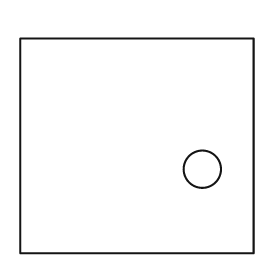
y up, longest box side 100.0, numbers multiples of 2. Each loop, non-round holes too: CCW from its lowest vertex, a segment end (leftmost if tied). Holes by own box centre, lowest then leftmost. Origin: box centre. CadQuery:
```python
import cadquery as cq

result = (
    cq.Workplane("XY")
    .moveTo(-50.0, -46.0)
    .lineTo(50.0, -46.0)
    .lineTo(50.0, 46.0)
    .lineTo(-50.0, 46.0)
    .close()
    .moveTo(28.0, -10.0)
    .circle(8.0)
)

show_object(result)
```